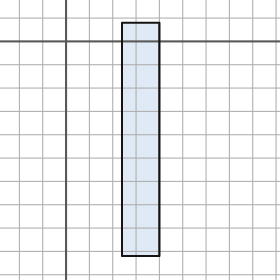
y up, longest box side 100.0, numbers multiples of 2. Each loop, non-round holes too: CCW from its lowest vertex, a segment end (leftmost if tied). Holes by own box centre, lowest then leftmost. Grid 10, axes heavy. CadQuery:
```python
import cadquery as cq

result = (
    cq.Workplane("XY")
    .moveTo(24.0, -92.0)
    .lineTo(40.0, -92.0)
    .lineTo(40.0, 8.0)
    .lineTo(24.0, 8.0)
    .close()
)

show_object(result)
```